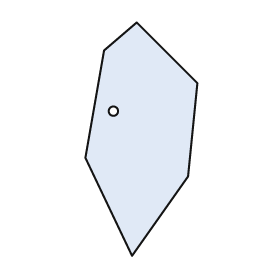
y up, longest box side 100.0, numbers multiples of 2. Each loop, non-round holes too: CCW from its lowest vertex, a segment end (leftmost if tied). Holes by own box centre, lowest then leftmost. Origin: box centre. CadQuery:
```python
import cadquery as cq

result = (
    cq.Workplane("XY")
    .moveTo(-4.0, -50.0)
    .lineTo(20.0, -16.0)
    .lineTo(24.0, 24.0)
    .lineTo(-2.0, 50.0)
    .lineTo(-16.0, 38.0)
    .lineTo(-24.0, -8.0)
    .close()
    .moveTo(-12.0, 12.0)
    .circle(2.0)
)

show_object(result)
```